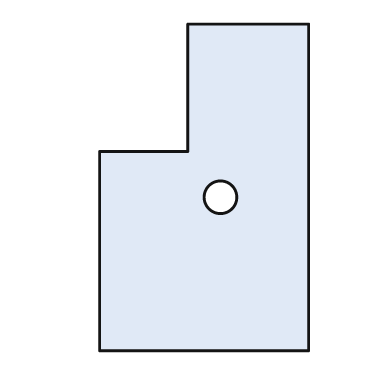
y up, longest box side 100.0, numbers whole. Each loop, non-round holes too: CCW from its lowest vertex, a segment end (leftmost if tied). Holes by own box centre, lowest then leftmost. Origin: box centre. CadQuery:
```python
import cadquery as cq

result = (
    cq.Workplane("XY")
    .moveTo(-32.0, -50.0)
    .lineTo(32.0, -50.0)
    .lineTo(32.0, 50.0)
    .lineTo(-5.0, 50.0)
    .lineTo(-5.0, 11.0)
    .lineTo(-32.0, 11.0)
    .close()
    .moveTo(5.0, -3.0)
    .circle(5.0)
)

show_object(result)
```